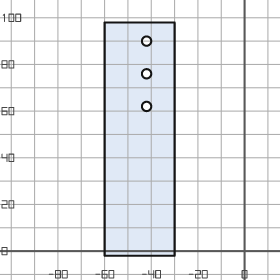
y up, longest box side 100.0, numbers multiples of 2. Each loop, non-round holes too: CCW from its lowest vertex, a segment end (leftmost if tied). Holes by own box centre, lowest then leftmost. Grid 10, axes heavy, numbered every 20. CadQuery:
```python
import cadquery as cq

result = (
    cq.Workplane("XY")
    .moveTo(-60.0, -2.0)
    .lineTo(-30.0, -2.0)
    .lineTo(-30.0, 98.0)
    .lineTo(-60.0, 98.0)
    .close()
    .moveTo(-42.0, 62.0)
    .circle(2.0)
    .moveTo(-42.0, 76.0)
    .circle(2.0)
    .moveTo(-42.0, 90.0)
    .circle(2.0)
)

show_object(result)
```